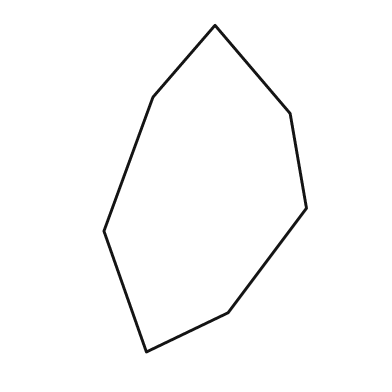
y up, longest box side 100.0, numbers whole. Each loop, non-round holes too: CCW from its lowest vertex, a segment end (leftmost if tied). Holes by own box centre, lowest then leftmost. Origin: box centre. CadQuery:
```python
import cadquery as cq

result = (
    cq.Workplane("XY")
    .moveTo(-18.0, -50.0)
    .lineTo(7.0, -38.0)
    .lineTo(31.0, -6.0)
    .lineTo(26.0, 23.0)
    .lineTo(3.0, 50.0)
    .lineTo(-16.0, 28.0)
    .lineTo(-31.0, -13.0)
    .close()
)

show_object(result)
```